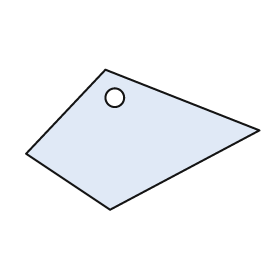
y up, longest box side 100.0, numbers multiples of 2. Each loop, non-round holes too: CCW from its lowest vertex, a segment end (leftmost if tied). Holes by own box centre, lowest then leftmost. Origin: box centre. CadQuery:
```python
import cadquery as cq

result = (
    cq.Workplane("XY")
    .moveTo(-14.0, -30.0)
    .lineTo(50.0, 4.0)
    .lineTo(-16.0, 30.0)
    .lineTo(-50.0, -6.0)
    .close()
    .moveTo(-12.0, 18.0)
    .circle(4.0)
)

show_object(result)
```